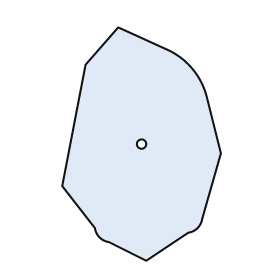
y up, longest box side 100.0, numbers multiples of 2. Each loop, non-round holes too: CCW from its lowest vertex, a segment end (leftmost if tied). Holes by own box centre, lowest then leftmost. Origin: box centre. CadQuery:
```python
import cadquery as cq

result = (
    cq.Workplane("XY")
    .moveTo(2.0, -50.0)
    .lineTo(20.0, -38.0)
    .threePointArc((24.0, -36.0), (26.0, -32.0))
    .lineTo(34.0, -4.0)
    .lineTo(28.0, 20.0)
    .threePointArc((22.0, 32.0), (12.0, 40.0))
    .lineTo(-10.0, 50.0)
    .lineTo(-24.0, 34.0)
    .lineTo(-34.0, -18.0)
    .lineTo(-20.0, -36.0)
    .threePointArc((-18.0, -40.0), (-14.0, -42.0))
    .close()
    .moveTo(0.0, 0.0)
    .circle(2.0)
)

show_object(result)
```